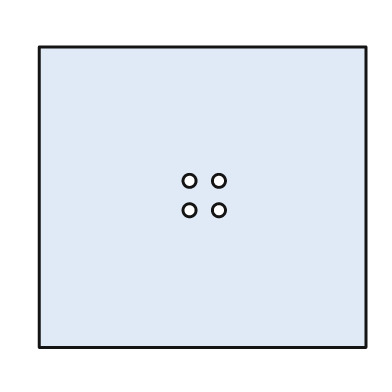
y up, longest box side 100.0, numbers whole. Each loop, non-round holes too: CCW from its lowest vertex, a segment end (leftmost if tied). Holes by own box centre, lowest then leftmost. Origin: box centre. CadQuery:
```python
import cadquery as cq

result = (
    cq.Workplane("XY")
    .moveTo(-50.0, -46.0)
    .lineTo(50.0, -46.0)
    .lineTo(50.0, 46.0)
    .lineTo(-50.0, 46.0)
    .close()
    .moveTo(-4.0, -4.0)
    .circle(2.0)
    .moveTo(5.0, -4.0)
    .circle(2.0)
    .moveTo(-4.0, 5.0)
    .circle(2.0)
    .moveTo(5.0, 5.0)
    .circle(2.0)
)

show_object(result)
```